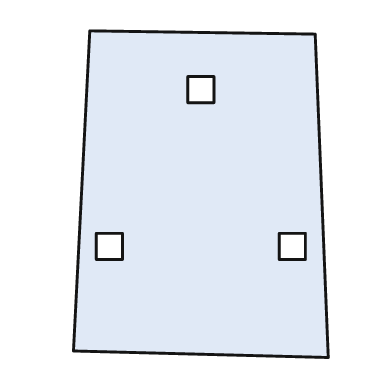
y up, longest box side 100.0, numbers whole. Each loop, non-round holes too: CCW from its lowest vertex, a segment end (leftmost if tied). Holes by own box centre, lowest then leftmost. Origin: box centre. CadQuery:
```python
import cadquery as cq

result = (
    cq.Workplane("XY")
    .moveTo(39.0, -50.0)
    .lineTo(35.0, 49.0)
    .lineTo(-34.0, 50.0)
    .lineTo(-39.0, -48.0)
    .close()
    .moveTo(-32.0, -20.0)
    .lineTo(-24.0, -20.0)
    .lineTo(-24.0, -12.0)
    .lineTo(-32.0, -12.0)
    .close()
    .moveTo(24.0, -20.0)
    .lineTo(32.0, -20.0)
    .lineTo(32.0, -12.0)
    .lineTo(24.0, -12.0)
    .close()
    .moveTo(-4.0, 28.0)
    .lineTo(4.0, 28.0)
    .lineTo(4.0, 36.0)
    .lineTo(-4.0, 36.0)
    .close()
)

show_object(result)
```